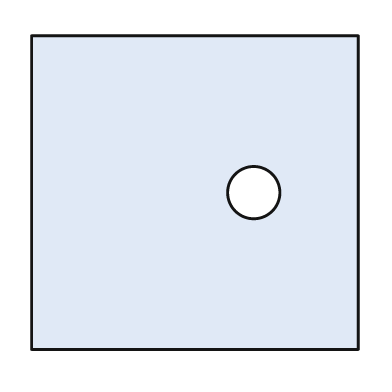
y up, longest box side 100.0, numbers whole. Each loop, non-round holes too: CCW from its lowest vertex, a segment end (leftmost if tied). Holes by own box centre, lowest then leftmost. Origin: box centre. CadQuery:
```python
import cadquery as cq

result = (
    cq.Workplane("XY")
    .moveTo(-50.0, -48.0)
    .lineTo(50.0, -48.0)
    .lineTo(50.0, 48.0)
    .lineTo(-50.0, 48.0)
    .close()
    .moveTo(18.0, 0.0)
    .circle(8.0)
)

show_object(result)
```